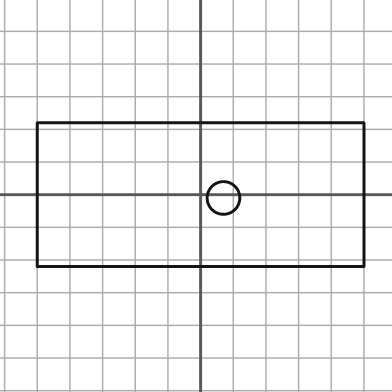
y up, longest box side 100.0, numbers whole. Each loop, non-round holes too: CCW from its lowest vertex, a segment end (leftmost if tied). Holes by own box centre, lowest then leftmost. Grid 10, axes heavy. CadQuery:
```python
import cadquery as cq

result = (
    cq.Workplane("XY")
    .moveTo(-50.0, -22.0)
    .lineTo(50.0, -22.0)
    .lineTo(50.0, 22.0)
    .lineTo(-50.0, 22.0)
    .close()
    .moveTo(7.0, -1.0)
    .circle(5.0)
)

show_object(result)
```